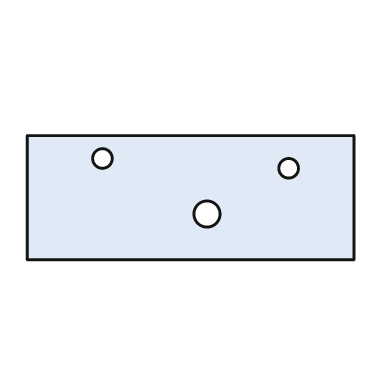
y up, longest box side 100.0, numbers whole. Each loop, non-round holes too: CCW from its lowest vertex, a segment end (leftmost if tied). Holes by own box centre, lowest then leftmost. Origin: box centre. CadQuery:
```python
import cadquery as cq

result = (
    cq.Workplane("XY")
    .moveTo(-50.0, -19.0)
    .lineTo(50.0, -19.0)
    .lineTo(50.0, 19.0)
    .lineTo(-50.0, 19.0)
    .close()
    .moveTo(5.0, -5.0)
    .circle(4.0)
    .moveTo(30.0, 9.0)
    .circle(3.0)
    .moveTo(-27.0, 12.0)
    .circle(3.0)
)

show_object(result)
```